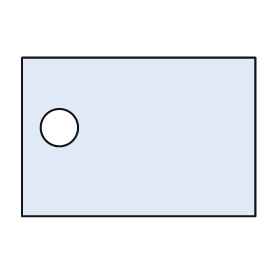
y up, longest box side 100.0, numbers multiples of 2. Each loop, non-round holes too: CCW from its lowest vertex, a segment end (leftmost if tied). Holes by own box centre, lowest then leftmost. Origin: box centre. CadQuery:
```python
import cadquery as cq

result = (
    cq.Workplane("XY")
    .moveTo(-50.0, -34.0)
    .lineTo(50.0, -34.0)
    .lineTo(50.0, 34.0)
    .lineTo(-50.0, 34.0)
    .close()
    .moveTo(-34.0, 4.0)
    .circle(8.0)
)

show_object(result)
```